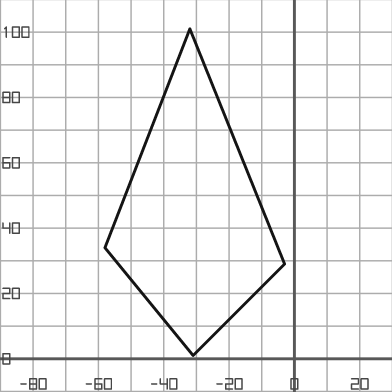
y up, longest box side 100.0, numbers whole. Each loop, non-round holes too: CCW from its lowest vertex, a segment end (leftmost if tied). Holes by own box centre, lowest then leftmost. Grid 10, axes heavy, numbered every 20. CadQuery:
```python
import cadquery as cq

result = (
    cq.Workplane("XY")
    .moveTo(-31.0, 1.0)
    .lineTo(-3.0, 29.0)
    .lineTo(-32.0, 101.0)
    .lineTo(-58.0, 34.0)
    .close()
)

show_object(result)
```